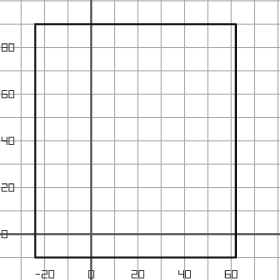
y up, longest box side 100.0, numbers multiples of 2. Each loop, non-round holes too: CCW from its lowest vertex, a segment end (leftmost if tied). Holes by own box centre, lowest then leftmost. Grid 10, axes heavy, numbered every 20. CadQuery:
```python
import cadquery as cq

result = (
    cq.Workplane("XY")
    .moveTo(-24.0, -10.0)
    .lineTo(62.0, -10.0)
    .lineTo(62.0, 90.0)
    .lineTo(-24.0, 90.0)
    .close()
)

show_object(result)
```